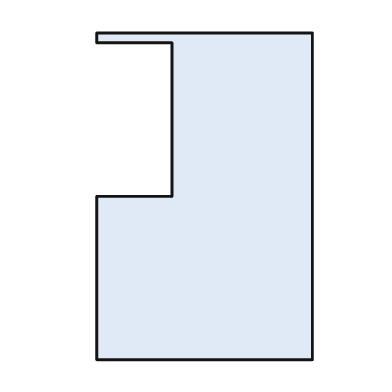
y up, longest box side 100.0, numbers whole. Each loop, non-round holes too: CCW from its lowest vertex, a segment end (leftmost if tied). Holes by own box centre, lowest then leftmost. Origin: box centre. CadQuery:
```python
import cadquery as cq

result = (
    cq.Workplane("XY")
    .moveTo(-33.0, -50.0)
    .lineTo(33.0, -50.0)
    .lineTo(33.0, 50.0)
    .lineTo(-33.0, 50.0)
    .lineTo(-33.0, 47.0)
    .lineTo(-10.0, 47.0)
    .lineTo(-10.0, 0.0)
    .lineTo(-33.0, 0.0)
    .close()
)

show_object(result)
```